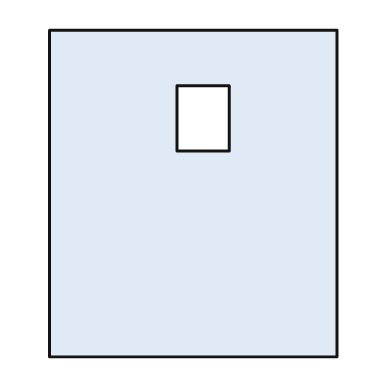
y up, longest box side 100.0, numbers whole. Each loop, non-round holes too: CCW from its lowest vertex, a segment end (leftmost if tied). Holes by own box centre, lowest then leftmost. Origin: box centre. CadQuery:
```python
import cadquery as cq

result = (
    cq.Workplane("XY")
    .moveTo(-44.0, -50.0)
    .lineTo(44.0, -50.0)
    .lineTo(44.0, 50.0)
    .lineTo(-44.0, 50.0)
    .close()
    .moveTo(-5.0, 13.0)
    .lineTo(11.0, 13.0)
    .lineTo(11.0, 33.0)
    .lineTo(-5.0, 33.0)
    .close()
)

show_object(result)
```